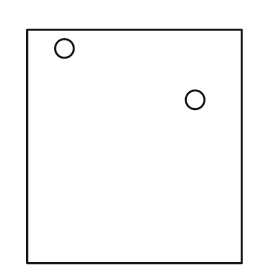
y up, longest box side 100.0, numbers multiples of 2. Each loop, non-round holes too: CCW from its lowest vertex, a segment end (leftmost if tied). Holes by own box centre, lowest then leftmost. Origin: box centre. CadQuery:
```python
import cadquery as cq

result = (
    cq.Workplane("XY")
    .moveTo(-46.0, -50.0)
    .lineTo(46.0, -50.0)
    .lineTo(46.0, 50.0)
    .lineTo(-46.0, 50.0)
    .close()
    .moveTo(26.0, 20.0)
    .circle(4.0)
    .moveTo(-30.0, 42.0)
    .circle(4.0)
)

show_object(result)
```